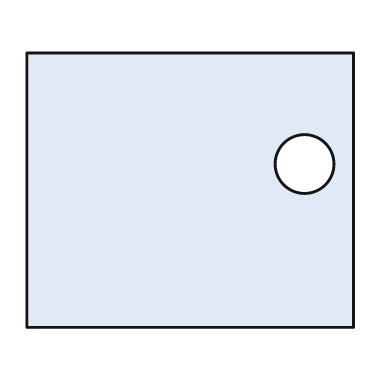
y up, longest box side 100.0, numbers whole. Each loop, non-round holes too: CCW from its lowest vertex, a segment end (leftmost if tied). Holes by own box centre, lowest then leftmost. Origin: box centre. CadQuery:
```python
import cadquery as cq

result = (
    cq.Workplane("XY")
    .moveTo(-50.0, -42.0)
    .lineTo(50.0, -42.0)
    .lineTo(50.0, 42.0)
    .lineTo(-50.0, 42.0)
    .close()
    .moveTo(35.0, 8.0)
    .circle(9.0)
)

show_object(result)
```